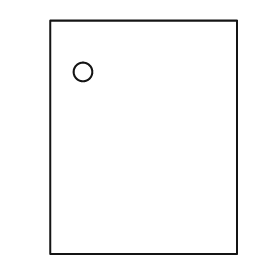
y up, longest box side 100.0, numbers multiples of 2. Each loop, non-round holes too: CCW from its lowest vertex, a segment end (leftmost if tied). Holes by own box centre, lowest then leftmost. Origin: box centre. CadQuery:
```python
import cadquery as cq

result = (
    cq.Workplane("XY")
    .moveTo(-40.0, -50.0)
    .lineTo(40.0, -50.0)
    .lineTo(40.0, 50.0)
    .lineTo(-40.0, 50.0)
    .close()
    .moveTo(-26.0, 28.0)
    .circle(4.0)
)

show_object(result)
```